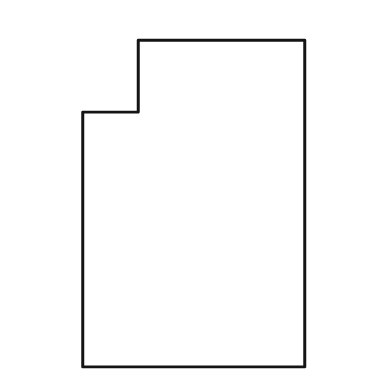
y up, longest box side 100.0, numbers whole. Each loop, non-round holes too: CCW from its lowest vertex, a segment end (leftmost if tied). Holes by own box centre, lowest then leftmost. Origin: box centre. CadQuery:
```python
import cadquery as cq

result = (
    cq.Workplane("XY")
    .moveTo(-34.0, -50.0)
    .lineTo(34.0, -50.0)
    .lineTo(34.0, 50.0)
    .lineTo(-17.0, 50.0)
    .lineTo(-17.0, 28.0)
    .lineTo(-34.0, 28.0)
    .close()
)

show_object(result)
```